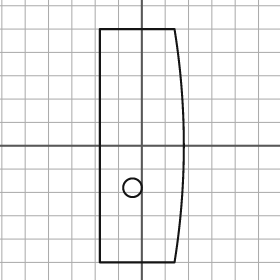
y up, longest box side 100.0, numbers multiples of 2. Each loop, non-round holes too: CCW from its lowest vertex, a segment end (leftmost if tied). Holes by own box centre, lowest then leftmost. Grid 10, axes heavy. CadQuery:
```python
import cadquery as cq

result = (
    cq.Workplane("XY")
    .moveTo(-18.0, -50.0)
    .lineTo(14.0, -50.0)
    .threePointArc((18.0, 0.0), (14.0, 50.0))
    .lineTo(-18.0, 50.0)
    .close()
    .moveTo(-4.0, -18.0)
    .circle(4.0)
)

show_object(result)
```